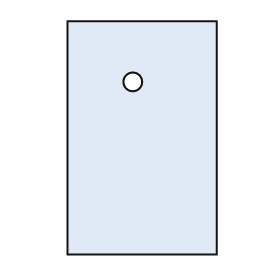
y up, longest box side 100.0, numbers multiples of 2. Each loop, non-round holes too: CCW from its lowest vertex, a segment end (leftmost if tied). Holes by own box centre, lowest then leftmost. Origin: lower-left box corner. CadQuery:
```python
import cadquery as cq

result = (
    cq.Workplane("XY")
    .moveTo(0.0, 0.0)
    .lineTo(64.0, 0.0)
    .lineTo(64.0, 100.0)
    .lineTo(0.0, 100.0)
    .close()
    .moveTo(28.0, 74.0)
    .circle(4.0)
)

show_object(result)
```